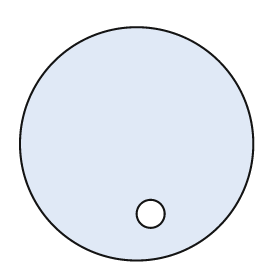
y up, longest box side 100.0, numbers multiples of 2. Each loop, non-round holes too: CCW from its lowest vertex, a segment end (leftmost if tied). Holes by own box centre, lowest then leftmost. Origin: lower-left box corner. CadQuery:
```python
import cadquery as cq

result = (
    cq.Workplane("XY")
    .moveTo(50.0, 50.0)
    .circle(50.0)
    .moveTo(56.0, 20.0)
    .circle(6.0)
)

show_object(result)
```